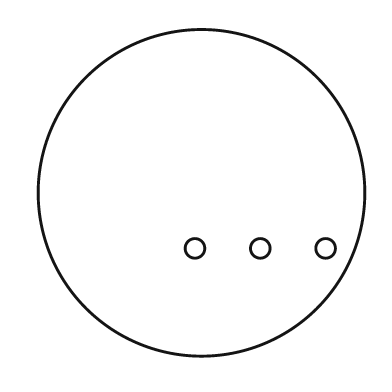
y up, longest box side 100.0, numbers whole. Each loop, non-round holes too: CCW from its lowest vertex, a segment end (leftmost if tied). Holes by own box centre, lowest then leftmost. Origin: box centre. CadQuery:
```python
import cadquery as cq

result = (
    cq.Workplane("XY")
    .moveTo(0.0, 0.0)
    .circle(50.0)
    .moveTo(-2.0, -17.0)
    .circle(3.0)
    .moveTo(18.0, -17.0)
    .circle(3.0)
    .moveTo(38.0, -17.0)
    .circle(3.0)
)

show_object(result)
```